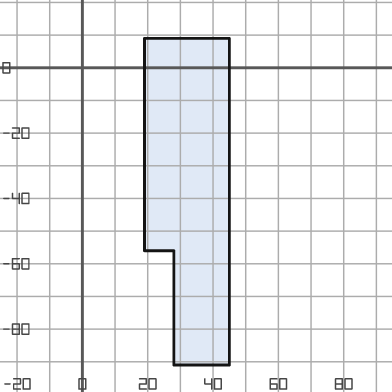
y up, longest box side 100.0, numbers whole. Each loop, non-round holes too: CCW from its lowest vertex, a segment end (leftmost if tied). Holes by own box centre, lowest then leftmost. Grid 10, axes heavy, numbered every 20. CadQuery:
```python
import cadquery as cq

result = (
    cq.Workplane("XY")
    .moveTo(28.0, -91.0)
    .lineTo(45.0, -91.0)
    .lineTo(45.0, 9.0)
    .lineTo(19.0, 9.0)
    .lineTo(19.0, -56.0)
    .lineTo(28.0, -56.0)
    .close()
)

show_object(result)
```